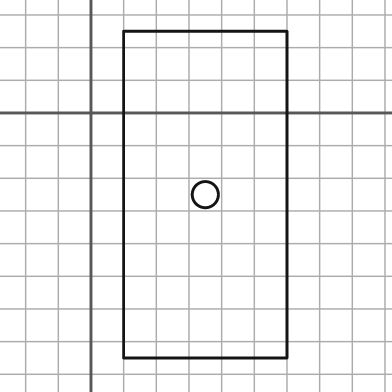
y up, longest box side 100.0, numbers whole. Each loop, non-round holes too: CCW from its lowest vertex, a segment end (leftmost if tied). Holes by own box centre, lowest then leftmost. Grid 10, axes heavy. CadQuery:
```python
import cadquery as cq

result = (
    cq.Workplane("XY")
    .moveTo(10.0, -75.0)
    .lineTo(60.0, -75.0)
    .lineTo(60.0, 25.0)
    .lineTo(10.0, 25.0)
    .close()
    .moveTo(35.0, -25.0)
    .circle(4.0)
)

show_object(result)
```